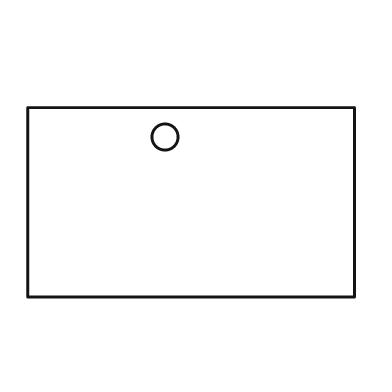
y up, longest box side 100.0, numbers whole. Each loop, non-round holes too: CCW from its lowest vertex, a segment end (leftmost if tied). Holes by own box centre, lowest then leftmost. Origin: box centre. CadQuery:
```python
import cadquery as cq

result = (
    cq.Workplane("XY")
    .moveTo(-50.0, -29.0)
    .lineTo(50.0, -29.0)
    .lineTo(50.0, 29.0)
    .lineTo(-50.0, 29.0)
    .close()
    .moveTo(-8.0, 20.0)
    .circle(4.0)
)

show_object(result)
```